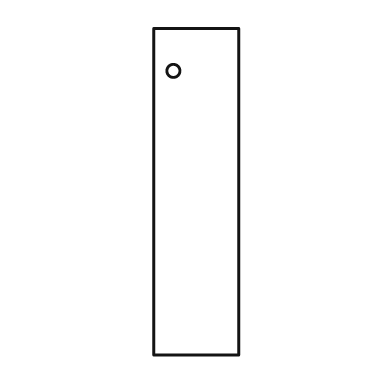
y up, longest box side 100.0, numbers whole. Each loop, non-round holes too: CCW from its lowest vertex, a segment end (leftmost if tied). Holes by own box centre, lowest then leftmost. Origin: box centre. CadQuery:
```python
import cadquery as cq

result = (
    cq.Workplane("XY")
    .moveTo(-13.0, -50.0)
    .lineTo(13.0, -50.0)
    .lineTo(13.0, 50.0)
    .lineTo(-13.0, 50.0)
    .close()
    .moveTo(-7.0, 37.0)
    .circle(2.0)
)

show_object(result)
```